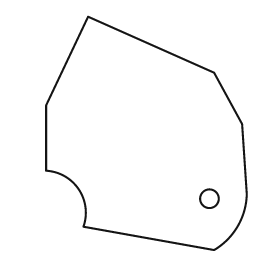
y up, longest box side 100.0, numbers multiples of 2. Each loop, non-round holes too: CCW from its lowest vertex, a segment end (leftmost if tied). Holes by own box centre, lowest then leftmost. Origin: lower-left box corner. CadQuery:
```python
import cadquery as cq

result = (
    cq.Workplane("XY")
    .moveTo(72.0, 0.0)
    .threePointArc((82.0, 10.0), (86.0, 24.0))
    .lineTo(84.0, 54.0)
    .lineTo(72.0, 76.0)
    .lineTo(18.0, 100.0)
    .lineTo(0.0, 62.0)
    .lineTo(0.0, 34.0)
    .threePointArc((14.0, 26.0), (16.0, 10.0))
    .close()
    .moveTo(70.0, 22.0)
    .circle(4.0)
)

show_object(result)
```